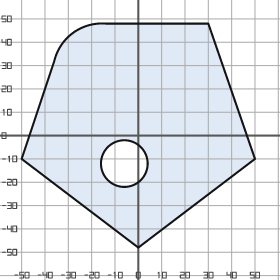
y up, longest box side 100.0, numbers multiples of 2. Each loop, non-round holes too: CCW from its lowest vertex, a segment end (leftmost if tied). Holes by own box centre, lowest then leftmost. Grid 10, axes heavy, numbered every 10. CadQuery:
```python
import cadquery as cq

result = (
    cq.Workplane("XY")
    .moveTo(0.0, -48.0)
    .lineTo(50.0, -10.0)
    .lineTo(30.0, 48.0)
    .lineTo(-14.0, 48.0)
    .threePointArc((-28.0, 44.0), (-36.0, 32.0))
    .lineTo(-50.0, -10.0)
    .close()
    .moveTo(-6.0, -12.0)
    .circle(10.0)
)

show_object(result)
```